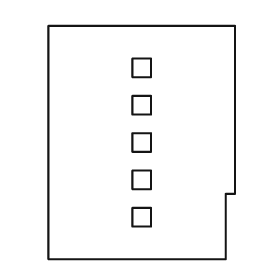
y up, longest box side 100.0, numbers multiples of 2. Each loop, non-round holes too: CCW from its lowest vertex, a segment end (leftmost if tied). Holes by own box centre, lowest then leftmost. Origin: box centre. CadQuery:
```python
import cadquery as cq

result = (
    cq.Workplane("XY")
    .moveTo(-40.0, -50.0)
    .lineTo(36.0, -50.0)
    .lineTo(36.0, -22.0)
    .lineTo(40.0, -22.0)
    .lineTo(40.0, 50.0)
    .lineTo(-40.0, 50.0)
    .close()
    .moveTo(-4.0, -36.0)
    .lineTo(4.0, -36.0)
    .lineTo(4.0, -28.0)
    .lineTo(-4.0, -28.0)
    .close()
    .moveTo(-4.0, -20.0)
    .lineTo(4.0, -20.0)
    .lineTo(4.0, -12.0)
    .lineTo(-4.0, -12.0)
    .close()
    .moveTo(-4.0, -4.0)
    .lineTo(4.0, -4.0)
    .lineTo(4.0, 4.0)
    .lineTo(-4.0, 4.0)
    .close()
    .moveTo(-4.0, 12.0)
    .lineTo(4.0, 12.0)
    .lineTo(4.0, 20.0)
    .lineTo(-4.0, 20.0)
    .close()
    .moveTo(-4.0, 28.0)
    .lineTo(4.0, 28.0)
    .lineTo(4.0, 36.0)
    .lineTo(-4.0, 36.0)
    .close()
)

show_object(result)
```